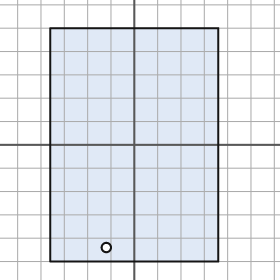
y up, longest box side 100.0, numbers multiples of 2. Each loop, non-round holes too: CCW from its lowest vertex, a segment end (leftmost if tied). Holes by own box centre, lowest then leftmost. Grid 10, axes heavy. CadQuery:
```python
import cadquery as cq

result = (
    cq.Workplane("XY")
    .moveTo(-36.0, -50.0)
    .lineTo(36.0, -50.0)
    .lineTo(36.0, 50.0)
    .lineTo(-36.0, 50.0)
    .close()
    .moveTo(-12.0, -44.0)
    .circle(2.0)
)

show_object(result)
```